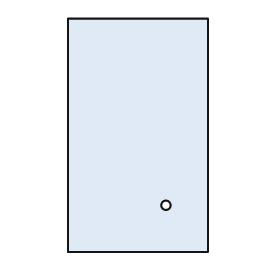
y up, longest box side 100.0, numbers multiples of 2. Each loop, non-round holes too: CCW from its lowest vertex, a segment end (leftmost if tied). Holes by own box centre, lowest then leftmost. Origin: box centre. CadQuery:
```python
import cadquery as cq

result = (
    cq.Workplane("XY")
    .moveTo(-30.0, -50.0)
    .lineTo(30.0, -50.0)
    .lineTo(30.0, 50.0)
    .lineTo(-30.0, 50.0)
    .close()
    .moveTo(12.0, -30.0)
    .circle(2.0)
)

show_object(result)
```